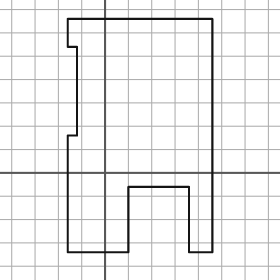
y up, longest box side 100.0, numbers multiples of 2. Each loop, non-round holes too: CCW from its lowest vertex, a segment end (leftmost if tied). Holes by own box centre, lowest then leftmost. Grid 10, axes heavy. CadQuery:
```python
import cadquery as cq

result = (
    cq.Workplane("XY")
    .moveTo(-16.0, -34.0)
    .lineTo(10.0, -34.0)
    .lineTo(10.0, -6.0)
    .lineTo(36.0, -6.0)
    .lineTo(36.0, -34.0)
    .lineTo(46.0, -34.0)
    .lineTo(46.0, 66.0)
    .lineTo(-16.0, 66.0)
    .lineTo(-16.0, 54.0)
    .lineTo(-12.0, 54.0)
    .lineTo(-12.0, 16.0)
    .lineTo(-16.0, 16.0)
    .close()
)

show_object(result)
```